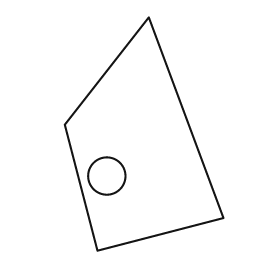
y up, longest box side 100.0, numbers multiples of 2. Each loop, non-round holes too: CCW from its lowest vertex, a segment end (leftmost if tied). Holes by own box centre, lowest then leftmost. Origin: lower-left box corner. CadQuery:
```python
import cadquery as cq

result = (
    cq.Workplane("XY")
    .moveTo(14.0, 0.0)
    .lineTo(68.0, 14.0)
    .lineTo(36.0, 100.0)
    .lineTo(0.0, 54.0)
    .close()
    .moveTo(18.0, 32.0)
    .circle(8.0)
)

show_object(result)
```